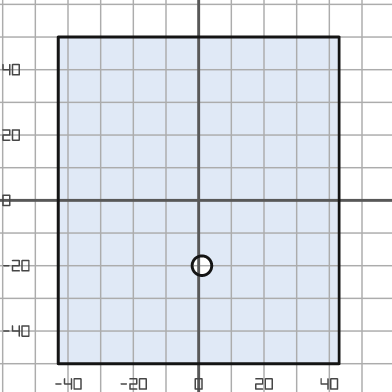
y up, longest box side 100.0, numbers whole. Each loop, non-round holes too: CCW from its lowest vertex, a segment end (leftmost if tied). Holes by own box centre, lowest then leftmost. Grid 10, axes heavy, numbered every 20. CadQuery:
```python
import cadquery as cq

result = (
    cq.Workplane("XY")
    .moveTo(-43.0, -50.0)
    .lineTo(43.0, -50.0)
    .lineTo(43.0, 50.0)
    .lineTo(-43.0, 50.0)
    .close()
    .moveTo(1.0, -20.0)
    .circle(3.0)
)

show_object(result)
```